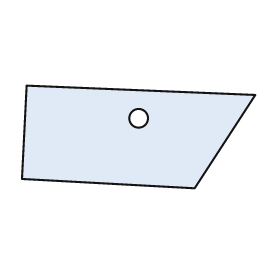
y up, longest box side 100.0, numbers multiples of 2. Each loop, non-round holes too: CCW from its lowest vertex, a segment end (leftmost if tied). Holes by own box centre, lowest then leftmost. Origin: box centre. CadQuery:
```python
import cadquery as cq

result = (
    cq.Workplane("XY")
    .moveTo(24.0, -22.0)
    .lineTo(50.0, 18.0)
    .lineTo(-48.0, 22.0)
    .lineTo(-50.0, -18.0)
    .close()
    .moveTo(0.0, 8.0)
    .circle(4.0)
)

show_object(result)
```